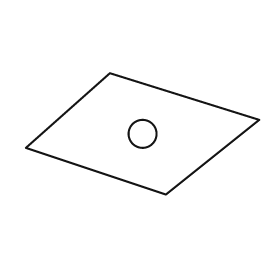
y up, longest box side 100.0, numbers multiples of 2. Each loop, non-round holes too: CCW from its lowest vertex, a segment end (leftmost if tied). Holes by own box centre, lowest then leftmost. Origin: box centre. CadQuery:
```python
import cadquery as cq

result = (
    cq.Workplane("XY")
    .moveTo(10.0, -26.0)
    .lineTo(50.0, 6.0)
    .lineTo(-14.0, 26.0)
    .lineTo(-50.0, -6.0)
    .close()
    .moveTo(0.0, 0.0)
    .circle(6.0)
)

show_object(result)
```